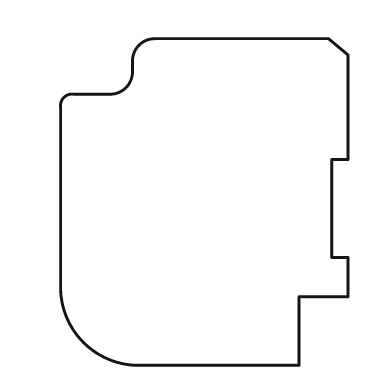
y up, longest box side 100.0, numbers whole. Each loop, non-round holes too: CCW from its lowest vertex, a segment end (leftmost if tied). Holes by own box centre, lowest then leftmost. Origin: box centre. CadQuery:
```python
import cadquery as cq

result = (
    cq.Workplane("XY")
    .moveTo(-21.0, -50.0)
    .lineTo(29.0, -50.0)
    .lineTo(29.0, -29.0)
    .lineTo(44.0, -29.0)
    .lineTo(44.0, -17.0)
    .lineTo(39.0, -17.0)
    .lineTo(39.0, 13.0)
    .lineTo(44.0, 13.0)
    .lineTo(44.0, 45.0)
    .lineTo(38.0, 50.0)
    .lineTo(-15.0, 50.0)
    .threePointArc((-20.0, 48.0), (-22.0, 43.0))
    .lineTo(-22.0, 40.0)
    .threePointArc((-24.0, 35.0), (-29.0, 33.0))
    .lineTo(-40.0, 33.0)
    .threePointArc((-43.0, 32.0), (-44.0, 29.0))
    .lineTo(-44.0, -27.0)
    .threePointArc((-37.0, -43.0), (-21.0, -50.0))
    .close()
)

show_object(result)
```